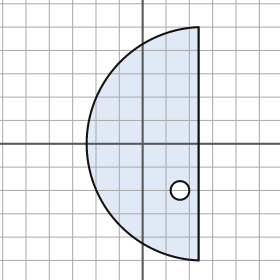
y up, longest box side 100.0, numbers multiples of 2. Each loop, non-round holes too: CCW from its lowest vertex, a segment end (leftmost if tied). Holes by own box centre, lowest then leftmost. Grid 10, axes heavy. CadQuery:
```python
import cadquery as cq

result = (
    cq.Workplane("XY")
    .moveTo(24.0, -50.0)
    .lineTo(24.0, 50.0)
    .threePointArc((-24.0, 0.0), (24.0, -50.0))
    .close()
    .moveTo(16.0, -20.0)
    .circle(4.0)
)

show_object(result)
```